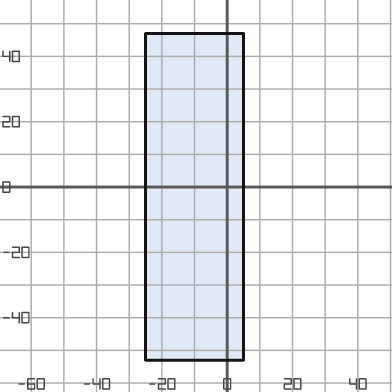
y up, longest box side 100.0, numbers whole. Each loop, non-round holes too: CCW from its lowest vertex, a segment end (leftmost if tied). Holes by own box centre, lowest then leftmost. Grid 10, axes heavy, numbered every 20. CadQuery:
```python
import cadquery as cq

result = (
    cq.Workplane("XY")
    .moveTo(-25.0, -53.0)
    .lineTo(5.0, -53.0)
    .lineTo(5.0, 47.0)
    .lineTo(-25.0, 47.0)
    .close()
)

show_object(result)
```